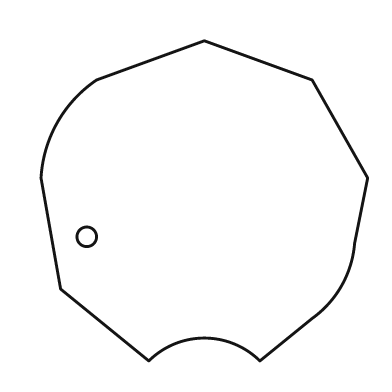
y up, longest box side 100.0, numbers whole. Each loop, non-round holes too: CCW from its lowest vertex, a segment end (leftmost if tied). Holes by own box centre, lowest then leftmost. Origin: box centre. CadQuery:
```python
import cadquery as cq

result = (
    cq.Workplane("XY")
    .moveTo(-17.0, -49.0)
    .threePointArc((0.0, -42.0), (17.0, -49.0))
    .lineTo(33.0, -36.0)
    .threePointArc((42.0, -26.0), (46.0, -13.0))
    .lineTo(50.0, 7.0)
    .lineTo(33.0, 37.0)
    .lineTo(0.0, 49.0)
    .lineTo(-33.0, 37.0)
    .threePointArc((-45.0, 24.0), (-50.0, 7.0))
    .lineTo(-44.0, -27.0)
    .close()
    .moveTo(-36.0, -11.0)
    .circle(3.0)
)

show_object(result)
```